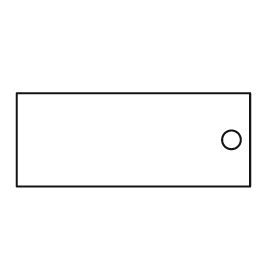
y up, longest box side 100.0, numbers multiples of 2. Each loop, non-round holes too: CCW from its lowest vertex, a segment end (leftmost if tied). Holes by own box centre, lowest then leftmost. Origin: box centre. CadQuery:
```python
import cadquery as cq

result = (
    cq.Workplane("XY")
    .moveTo(-50.0, -20.0)
    .lineTo(50.0, -20.0)
    .lineTo(50.0, 20.0)
    .lineTo(-50.0, 20.0)
    .close()
    .moveTo(42.0, 0.0)
    .circle(4.0)
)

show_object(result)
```